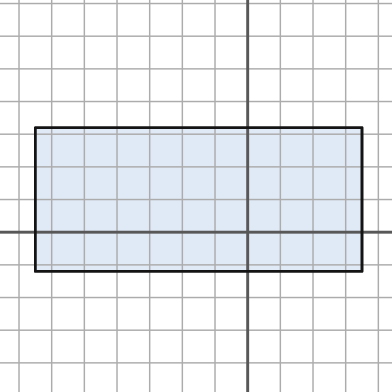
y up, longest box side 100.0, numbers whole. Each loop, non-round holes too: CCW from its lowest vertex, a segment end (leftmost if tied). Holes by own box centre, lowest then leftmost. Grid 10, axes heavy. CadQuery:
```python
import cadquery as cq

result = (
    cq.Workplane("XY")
    .moveTo(-65.0, -12.0)
    .lineTo(35.0, -12.0)
    .lineTo(35.0, 32.0)
    .lineTo(-65.0, 32.0)
    .close()
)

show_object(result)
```